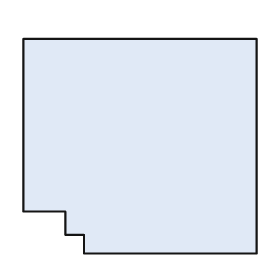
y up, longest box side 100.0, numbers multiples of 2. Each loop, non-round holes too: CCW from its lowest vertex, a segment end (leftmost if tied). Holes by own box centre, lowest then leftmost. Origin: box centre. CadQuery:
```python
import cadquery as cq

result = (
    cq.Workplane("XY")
    .moveTo(-24.0, -46.0)
    .lineTo(50.0, -46.0)
    .lineTo(50.0, 46.0)
    .lineTo(-50.0, 46.0)
    .lineTo(-50.0, -28.0)
    .lineTo(-32.0, -28.0)
    .lineTo(-32.0, -38.0)
    .lineTo(-24.0, -38.0)
    .close()
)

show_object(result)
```